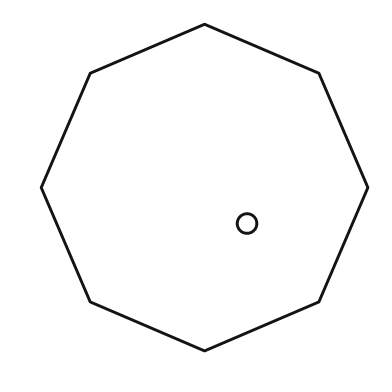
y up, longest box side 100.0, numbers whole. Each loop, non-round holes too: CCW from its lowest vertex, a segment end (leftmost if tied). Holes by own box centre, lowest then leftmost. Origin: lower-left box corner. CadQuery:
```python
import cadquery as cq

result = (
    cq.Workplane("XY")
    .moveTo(50.0, 0.0)
    .lineTo(85.0, 15.0)
    .lineTo(100.0, 50.0)
    .lineTo(85.0, 85.0)
    .lineTo(50.0, 100.0)
    .lineTo(15.0, 85.0)
    .lineTo(0.0, 50.0)
    .lineTo(15.0, 15.0)
    .close()
    .moveTo(63.0, 39.0)
    .circle(3.0)
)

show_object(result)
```